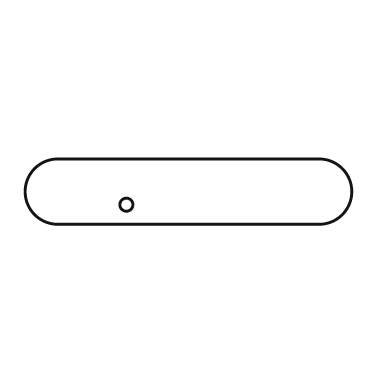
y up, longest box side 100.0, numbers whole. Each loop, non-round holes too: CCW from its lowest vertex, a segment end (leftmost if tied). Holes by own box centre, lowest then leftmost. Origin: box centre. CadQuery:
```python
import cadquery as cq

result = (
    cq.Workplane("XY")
    .moveTo(-40.0, -10.0)
    .lineTo(40.0, -10.0)
    .threePointArc((50.0, 0.0), (40.0, 10.0))
    .lineTo(-40.0, 10.0)
    .threePointArc((-50.0, 0.0), (-40.0, -10.0))
    .close()
    .moveTo(-19.0, -4.0)
    .circle(2.0)
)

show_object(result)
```